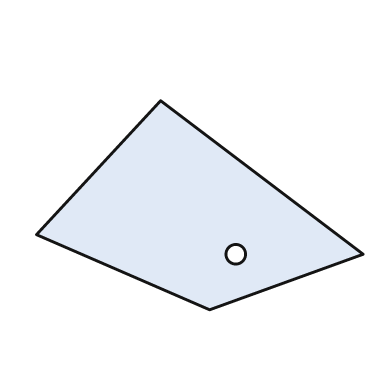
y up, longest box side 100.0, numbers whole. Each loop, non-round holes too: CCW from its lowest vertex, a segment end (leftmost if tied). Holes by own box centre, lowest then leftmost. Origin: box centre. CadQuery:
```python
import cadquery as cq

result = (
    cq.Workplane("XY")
    .moveTo(3.0, -32.0)
    .lineTo(50.0, -15.0)
    .lineTo(-12.0, 32.0)
    .lineTo(-50.0, -9.0)
    .close()
    .moveTo(11.0, -15.0)
    .circle(3.0)
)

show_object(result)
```